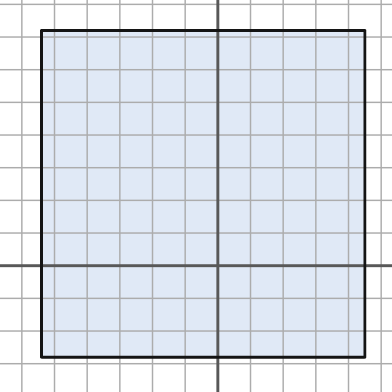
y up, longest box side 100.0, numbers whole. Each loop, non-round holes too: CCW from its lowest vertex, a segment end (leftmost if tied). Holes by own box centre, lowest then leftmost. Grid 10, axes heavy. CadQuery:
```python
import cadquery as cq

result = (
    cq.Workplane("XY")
    .moveTo(-54.0, -28.0)
    .lineTo(45.0, -28.0)
    .lineTo(45.0, 72.0)
    .lineTo(-54.0, 72.0)
    .close()
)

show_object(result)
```